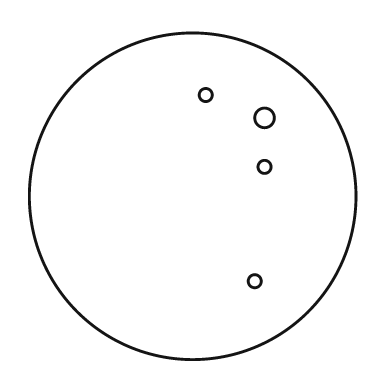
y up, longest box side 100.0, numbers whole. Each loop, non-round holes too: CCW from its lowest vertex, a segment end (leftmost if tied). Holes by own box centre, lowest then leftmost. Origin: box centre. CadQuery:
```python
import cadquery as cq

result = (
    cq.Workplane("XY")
    .moveTo(0.0, 0.0)
    .circle(50.0)
    .moveTo(19.0, -26.0)
    .circle(2.0)
    .moveTo(22.0, 9.0)
    .circle(2.0)
    .moveTo(22.0, 24.0)
    .circle(3.0)
    .moveTo(4.0, 31.0)
    .circle(2.0)
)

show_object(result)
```